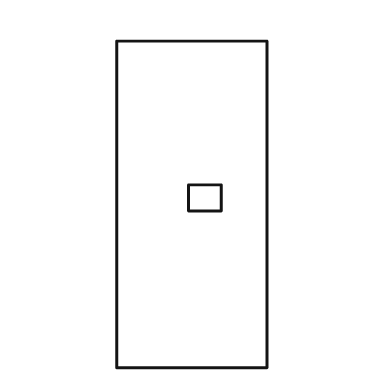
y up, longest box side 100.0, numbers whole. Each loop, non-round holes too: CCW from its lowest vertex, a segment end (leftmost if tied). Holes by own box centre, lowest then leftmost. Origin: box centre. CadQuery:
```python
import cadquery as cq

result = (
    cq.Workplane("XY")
    .moveTo(-23.0, -50.0)
    .lineTo(23.0, -50.0)
    .lineTo(23.0, 50.0)
    .lineTo(-23.0, 50.0)
    .close()
    .moveTo(-1.0, -2.0)
    .lineTo(9.0, -2.0)
    .lineTo(9.0, 6.0)
    .lineTo(-1.0, 6.0)
    .close()
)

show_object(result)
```